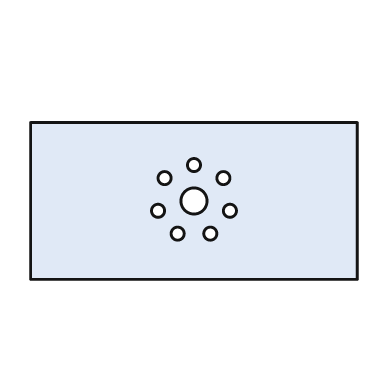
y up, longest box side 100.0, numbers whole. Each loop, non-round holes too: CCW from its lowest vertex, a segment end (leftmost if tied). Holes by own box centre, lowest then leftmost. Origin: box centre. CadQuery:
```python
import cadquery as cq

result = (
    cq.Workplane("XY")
    .moveTo(-50.0, -24.0)
    .lineTo(50.0, -24.0)
    .lineTo(50.0, 24.0)
    .lineTo(-50.0, 24.0)
    .close()
    .moveTo(-5.0, -10.0)
    .circle(2.0)
    .moveTo(5.0, -10.0)
    .circle(2.0)
    .moveTo(-11.0, -3.0)
    .circle(2.0)
    .moveTo(11.0, -3.0)
    .circle(2.0)
    .moveTo(0.0, 0.0)
    .circle(4.0)
    .moveTo(-9.0, 7.0)
    .circle(2.0)
    .moveTo(9.0, 7.0)
    .circle(2.0)
    .moveTo(0.0, 11.0)
    .circle(2.0)
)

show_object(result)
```